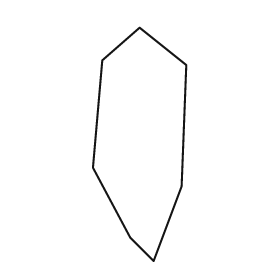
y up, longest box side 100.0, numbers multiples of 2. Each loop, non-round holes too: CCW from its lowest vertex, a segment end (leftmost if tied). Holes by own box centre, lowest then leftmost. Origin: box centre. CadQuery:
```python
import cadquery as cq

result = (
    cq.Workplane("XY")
    .moveTo(6.0, -50.0)
    .lineTo(18.0, -18.0)
    .lineTo(20.0, 34.0)
    .lineTo(0.0, 50.0)
    .lineTo(-16.0, 36.0)
    .lineTo(-20.0, -10.0)
    .lineTo(-4.0, -40.0)
    .close()
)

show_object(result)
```